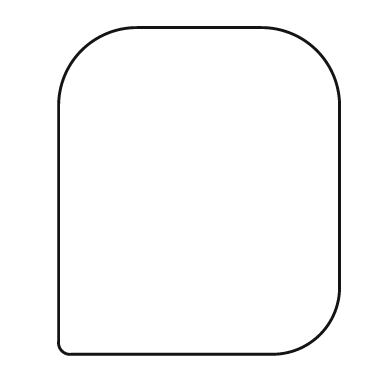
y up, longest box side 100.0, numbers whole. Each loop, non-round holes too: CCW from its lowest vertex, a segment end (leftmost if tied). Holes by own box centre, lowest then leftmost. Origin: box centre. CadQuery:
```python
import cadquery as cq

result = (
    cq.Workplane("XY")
    .moveTo(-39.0, -50.0)
    .lineTo(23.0, -50.0)
    .threePointArc((37.0, -44.0), (43.0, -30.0))
    .lineTo(43.0, 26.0)
    .threePointArc((36.0, 43.0), (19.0, 50.0))
    .lineTo(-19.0, 50.0)
    .threePointArc((-36.0, 43.0), (-43.0, 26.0))
    .lineTo(-43.0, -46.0)
    .threePointArc((-42.0, -49.0), (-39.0, -50.0))
    .close()
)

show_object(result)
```